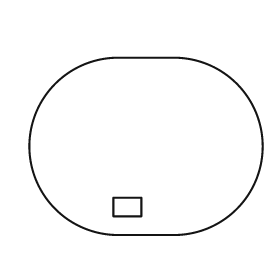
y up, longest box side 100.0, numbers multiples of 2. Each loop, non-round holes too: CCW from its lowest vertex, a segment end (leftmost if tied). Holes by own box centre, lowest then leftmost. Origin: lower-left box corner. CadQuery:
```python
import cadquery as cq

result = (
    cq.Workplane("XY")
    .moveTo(38.0, 0.0)
    .lineTo(62.0, 0.0)
    .threePointArc((100.0, 38.0), (62.0, 76.0))
    .lineTo(38.0, 76.0)
    .threePointArc((0.0, 38.0), (38.0, 0.0))
    .close()
    .moveTo(36.0, 8.0)
    .lineTo(48.0, 8.0)
    .lineTo(48.0, 16.0)
    .lineTo(36.0, 16.0)
    .close()
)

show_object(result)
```